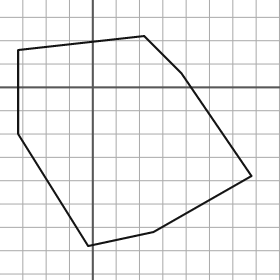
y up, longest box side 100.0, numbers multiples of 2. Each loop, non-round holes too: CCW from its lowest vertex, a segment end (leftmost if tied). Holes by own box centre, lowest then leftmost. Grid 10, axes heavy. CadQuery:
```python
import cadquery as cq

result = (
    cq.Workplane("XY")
    .moveTo(-2.0, -68.0)
    .lineTo(26.0, -62.0)
    .lineTo(68.0, -38.0)
    .lineTo(38.0, 6.0)
    .lineTo(22.0, 22.0)
    .lineTo(-32.0, 16.0)
    .lineTo(-32.0, -20.0)
    .close()
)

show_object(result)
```